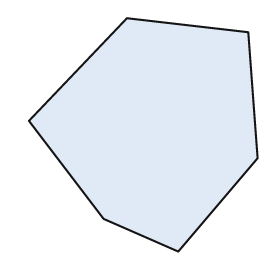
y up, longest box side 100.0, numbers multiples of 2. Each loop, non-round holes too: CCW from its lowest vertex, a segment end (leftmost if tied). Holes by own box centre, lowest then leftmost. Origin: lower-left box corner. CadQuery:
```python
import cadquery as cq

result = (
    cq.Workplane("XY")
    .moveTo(64.0, 0.0)
    .lineTo(98.0, 40.0)
    .lineTo(94.0, 94.0)
    .lineTo(42.0, 100.0)
    .lineTo(0.0, 56.0)
    .lineTo(32.0, 14.0)
    .close()
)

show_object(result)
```